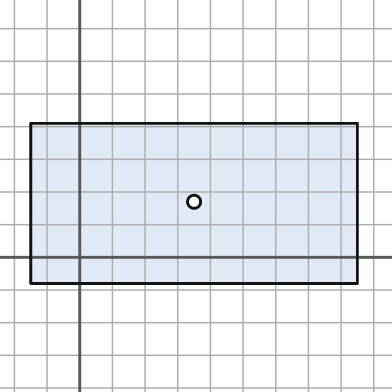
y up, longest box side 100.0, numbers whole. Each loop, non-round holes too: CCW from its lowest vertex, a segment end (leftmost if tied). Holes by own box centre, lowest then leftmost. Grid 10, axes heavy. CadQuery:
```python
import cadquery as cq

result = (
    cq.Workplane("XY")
    .moveTo(-15.0, -8.0)
    .lineTo(85.0, -8.0)
    .lineTo(85.0, 41.0)
    .lineTo(-15.0, 41.0)
    .close()
    .moveTo(35.0, 17.0)
    .circle(2.0)
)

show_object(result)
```